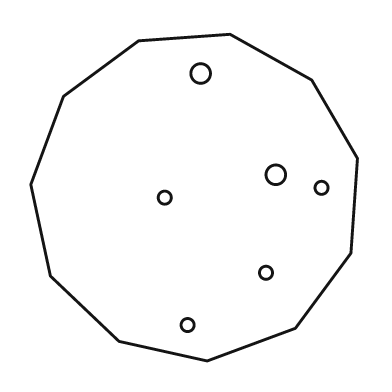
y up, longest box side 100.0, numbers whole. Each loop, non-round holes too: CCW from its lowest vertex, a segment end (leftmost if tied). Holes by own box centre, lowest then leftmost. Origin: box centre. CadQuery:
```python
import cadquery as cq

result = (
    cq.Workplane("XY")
    .moveTo(4.0, -50.0)
    .lineTo(31.0, -40.0)
    .lineTo(48.0, -17.0)
    .lineTo(50.0, 12.0)
    .lineTo(36.0, 36.0)
    .lineTo(11.0, 50.0)
    .lineTo(-17.0, 48.0)
    .lineTo(-40.0, 31.0)
    .lineTo(-50.0, 4.0)
    .lineTo(-44.0, -24.0)
    .lineTo(-23.0, -44.0)
    .close()
    .moveTo(-2.0, -39.0)
    .circle(2.0)
    .moveTo(22.0, -23.0)
    .circle(2.0)
    .moveTo(-9.0, 0.0)
    .circle(2.0)
    .moveTo(39.0, 3.0)
    .circle(2.0)
    .moveTo(25.0, 7.0)
    .circle(3.0)
    .moveTo(2.0, 38.0)
    .circle(3.0)
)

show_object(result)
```